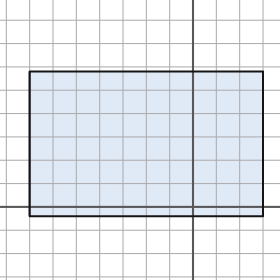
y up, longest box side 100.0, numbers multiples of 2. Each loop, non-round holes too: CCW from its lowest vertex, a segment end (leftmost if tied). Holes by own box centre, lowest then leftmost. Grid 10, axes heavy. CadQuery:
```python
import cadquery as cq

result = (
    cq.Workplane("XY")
    .moveTo(-70.0, -4.0)
    .lineTo(30.0, -4.0)
    .lineTo(30.0, 58.0)
    .lineTo(-70.0, 58.0)
    .close()
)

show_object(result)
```